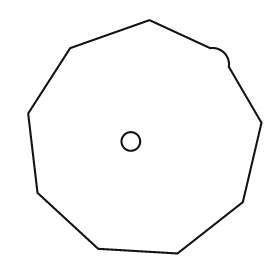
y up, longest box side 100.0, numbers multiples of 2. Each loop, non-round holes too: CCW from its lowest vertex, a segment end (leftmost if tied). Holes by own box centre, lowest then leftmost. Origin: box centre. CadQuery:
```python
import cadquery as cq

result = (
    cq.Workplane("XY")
    .moveTo(14.0, -50.0)
    .lineTo(42.0, -28.0)
    .lineTo(50.0, 6.0)
    .lineTo(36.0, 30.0)
    .threePointArc((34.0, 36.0), (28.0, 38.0))
    .lineTo(2.0, 50.0)
    .lineTo(-32.0, 38.0)
    .lineTo(-50.0, 10.0)
    .lineTo(-46.0, -24.0)
    .lineTo(-20.0, -48.0)
    .close()
    .moveTo(-6.0, -2.0)
    .circle(4.0)
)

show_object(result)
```